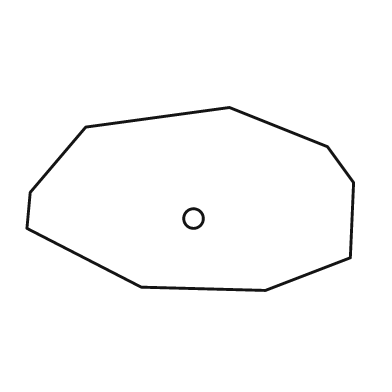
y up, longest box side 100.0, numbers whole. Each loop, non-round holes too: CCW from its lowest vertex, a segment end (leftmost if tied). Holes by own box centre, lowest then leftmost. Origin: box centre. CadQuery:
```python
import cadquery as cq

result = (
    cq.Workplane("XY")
    .moveTo(23.0, -28.0)
    .lineTo(49.0, -18.0)
    .lineTo(50.0, 5.0)
    .lineTo(42.0, 16.0)
    .lineTo(12.0, 28.0)
    .lineTo(-32.0, 22.0)
    .lineTo(-49.0, 2.0)
    .lineTo(-50.0, -9.0)
    .lineTo(-15.0, -27.0)
    .close()
    .moveTo(1.0, -6.0)
    .circle(3.0)
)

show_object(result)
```